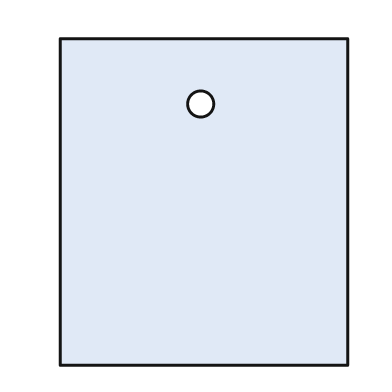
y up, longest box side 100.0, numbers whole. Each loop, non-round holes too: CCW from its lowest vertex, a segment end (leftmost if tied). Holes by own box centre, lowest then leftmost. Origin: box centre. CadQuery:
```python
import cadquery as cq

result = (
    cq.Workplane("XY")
    .moveTo(-44.0, -50.0)
    .lineTo(44.0, -50.0)
    .lineTo(44.0, 50.0)
    .lineTo(-44.0, 50.0)
    .close()
    .moveTo(-1.0, 30.0)
    .circle(4.0)
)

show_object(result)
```